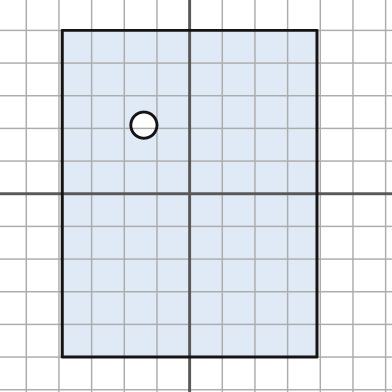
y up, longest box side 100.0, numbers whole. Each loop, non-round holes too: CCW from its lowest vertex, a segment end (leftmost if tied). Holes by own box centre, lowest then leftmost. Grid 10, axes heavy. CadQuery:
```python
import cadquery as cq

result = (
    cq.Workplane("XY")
    .moveTo(-39.0, -50.0)
    .lineTo(39.0, -50.0)
    .lineTo(39.0, 50.0)
    .lineTo(-39.0, 50.0)
    .close()
    .moveTo(-14.0, 21.0)
    .circle(4.0)
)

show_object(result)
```